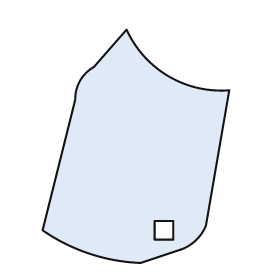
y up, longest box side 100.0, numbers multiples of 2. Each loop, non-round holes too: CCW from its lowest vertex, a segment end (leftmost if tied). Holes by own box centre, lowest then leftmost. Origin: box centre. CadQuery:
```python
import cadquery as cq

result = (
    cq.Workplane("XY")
    .moveTo(2.0, -50.0)
    .lineTo(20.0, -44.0)
    .threePointArc((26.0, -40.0), (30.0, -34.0))
    .lineTo(40.0, 24.0)
    .threePointArc((14.0, 30.0), (-4.0, 50.0))
    .lineTo(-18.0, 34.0)
    .threePointArc((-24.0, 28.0), (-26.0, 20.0))
    .lineTo(-40.0, -36.0)
    .threePointArc((-20.0, -46.0), (2.0, -50.0))
    .close()
    .moveTo(8.0, -40.0)
    .lineTo(16.0, -40.0)
    .lineTo(16.0, -32.0)
    .lineTo(8.0, -32.0)
    .close()
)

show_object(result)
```